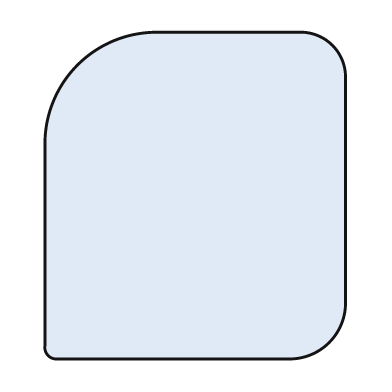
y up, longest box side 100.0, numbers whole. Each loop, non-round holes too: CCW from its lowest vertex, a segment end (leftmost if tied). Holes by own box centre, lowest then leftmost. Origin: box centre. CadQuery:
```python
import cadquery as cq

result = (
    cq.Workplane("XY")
    .moveTo(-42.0, -50.0)
    .lineTo(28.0, -50.0)
    .threePointArc((41.0, -45.0), (46.0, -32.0))
    .lineTo(46.0, 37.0)
    .threePointArc((42.0, 46.0), (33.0, 50.0))
    .lineTo(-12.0, 50.0)
    .threePointArc((-36.0, 40.0), (-46.0, 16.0))
    .lineTo(-46.0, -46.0)
    .threePointArc((-45.0, -49.0), (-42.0, -50.0))
    .close()
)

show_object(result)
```